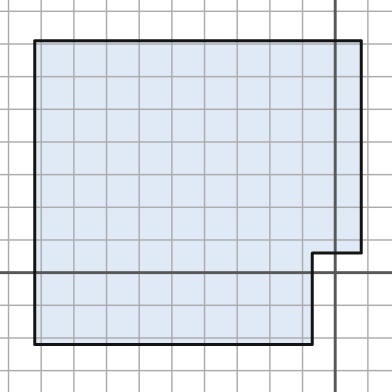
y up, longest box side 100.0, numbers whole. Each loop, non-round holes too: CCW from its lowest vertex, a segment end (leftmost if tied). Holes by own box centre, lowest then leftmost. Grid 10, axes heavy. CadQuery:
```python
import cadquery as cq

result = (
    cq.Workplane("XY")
    .moveTo(-92.0, -22.0)
    .lineTo(-7.0, -22.0)
    .lineTo(-7.0, 6.0)
    .lineTo(8.0, 6.0)
    .lineTo(8.0, 71.0)
    .lineTo(-92.0, 71.0)
    .close()
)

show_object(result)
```